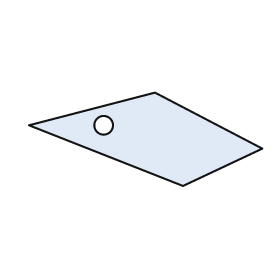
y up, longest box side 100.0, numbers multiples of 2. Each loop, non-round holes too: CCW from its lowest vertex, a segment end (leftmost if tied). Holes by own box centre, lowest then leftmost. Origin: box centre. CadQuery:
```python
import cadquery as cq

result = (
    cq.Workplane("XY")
    .moveTo(16.0, -20.0)
    .lineTo(50.0, -4.0)
    .lineTo(4.0, 20.0)
    .lineTo(-50.0, 6.0)
    .close()
    .moveTo(-18.0, 6.0)
    .circle(4.0)
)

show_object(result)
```